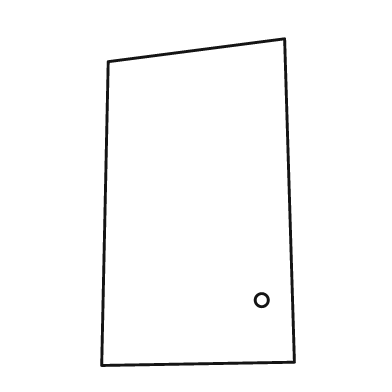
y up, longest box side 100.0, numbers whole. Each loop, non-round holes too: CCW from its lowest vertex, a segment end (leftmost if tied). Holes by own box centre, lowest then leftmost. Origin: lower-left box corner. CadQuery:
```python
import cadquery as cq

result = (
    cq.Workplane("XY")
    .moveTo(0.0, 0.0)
    .lineTo(59.0, 1.0)
    .lineTo(56.0, 100.0)
    .lineTo(2.0, 93.0)
    .close()
    .moveTo(49.0, 20.0)
    .circle(2.0)
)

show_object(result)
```